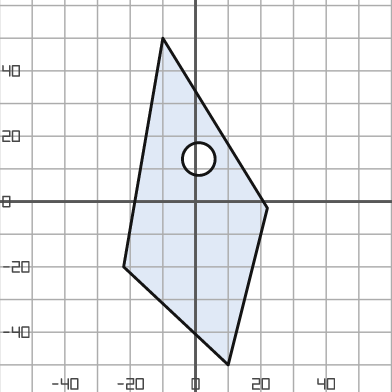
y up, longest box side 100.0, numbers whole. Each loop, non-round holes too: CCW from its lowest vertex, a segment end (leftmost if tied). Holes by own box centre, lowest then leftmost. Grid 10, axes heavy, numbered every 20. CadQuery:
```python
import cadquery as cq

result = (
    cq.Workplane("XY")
    .moveTo(10.0, -50.0)
    .lineTo(22.0, -2.0)
    .lineTo(-10.0, 50.0)
    .lineTo(-22.0, -20.0)
    .close()
    .moveTo(1.0, 13.0)
    .circle(5.0)
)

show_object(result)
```